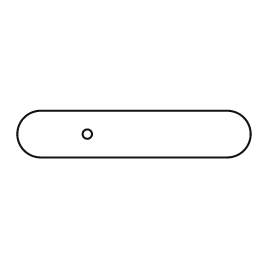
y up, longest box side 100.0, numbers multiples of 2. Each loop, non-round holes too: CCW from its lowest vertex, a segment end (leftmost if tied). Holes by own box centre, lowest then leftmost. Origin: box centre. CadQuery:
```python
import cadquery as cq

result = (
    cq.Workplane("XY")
    .moveTo(-40.0, -10.0)
    .lineTo(40.0, -10.0)
    .threePointArc((50.0, 0.0), (40.0, 10.0))
    .lineTo(-40.0, 10.0)
    .threePointArc((-50.0, 0.0), (-40.0, -10.0))
    .close()
    .moveTo(-20.0, 0.0)
    .circle(2.0)
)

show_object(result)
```